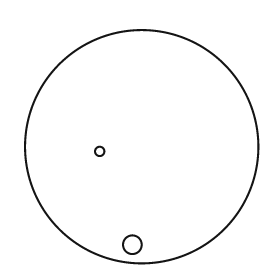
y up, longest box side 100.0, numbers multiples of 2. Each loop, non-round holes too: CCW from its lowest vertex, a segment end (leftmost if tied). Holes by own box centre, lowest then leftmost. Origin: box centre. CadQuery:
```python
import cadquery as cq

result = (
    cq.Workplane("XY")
    .moveTo(0.0, 0.0)
    .circle(50.0)
    .moveTo(-4.0, -42.0)
    .circle(4.0)
    .moveTo(-18.0, -2.0)
    .circle(2.0)
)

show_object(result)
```